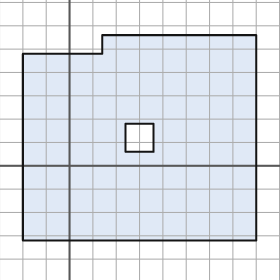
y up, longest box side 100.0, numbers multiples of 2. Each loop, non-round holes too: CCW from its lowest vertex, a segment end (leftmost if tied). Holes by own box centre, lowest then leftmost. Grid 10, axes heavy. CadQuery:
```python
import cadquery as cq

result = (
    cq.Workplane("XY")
    .moveTo(-20.0, -32.0)
    .lineTo(80.0, -32.0)
    .lineTo(80.0, 56.0)
    .lineTo(14.0, 56.0)
    .lineTo(14.0, 48.0)
    .lineTo(-20.0, 48.0)
    .close()
    .moveTo(24.0, 6.0)
    .lineTo(36.0, 6.0)
    .lineTo(36.0, 18.0)
    .lineTo(24.0, 18.0)
    .close()
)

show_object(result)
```